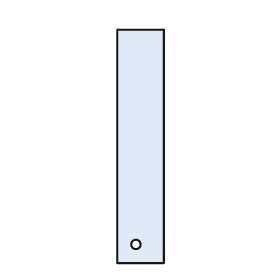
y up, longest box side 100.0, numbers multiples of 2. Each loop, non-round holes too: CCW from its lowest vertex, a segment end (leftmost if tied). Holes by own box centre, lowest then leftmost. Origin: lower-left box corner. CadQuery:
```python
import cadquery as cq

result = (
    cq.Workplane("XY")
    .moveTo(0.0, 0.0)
    .lineTo(20.0, 0.0)
    .lineTo(20.0, 100.0)
    .lineTo(0.0, 100.0)
    .close()
    .moveTo(8.0, 8.0)
    .circle(2.0)
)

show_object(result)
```